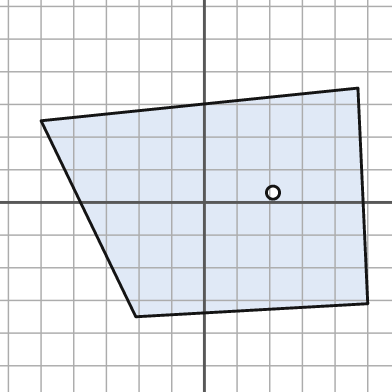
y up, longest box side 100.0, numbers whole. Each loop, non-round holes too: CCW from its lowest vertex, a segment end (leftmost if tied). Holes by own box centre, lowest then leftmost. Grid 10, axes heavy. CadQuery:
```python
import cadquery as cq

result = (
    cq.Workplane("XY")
    .moveTo(-21.0, -35.0)
    .lineTo(50.0, -31.0)
    .lineTo(47.0, 35.0)
    .lineTo(-50.0, 25.0)
    .close()
    .moveTo(21.0, 3.0)
    .circle(2.0)
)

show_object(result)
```